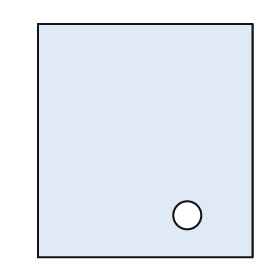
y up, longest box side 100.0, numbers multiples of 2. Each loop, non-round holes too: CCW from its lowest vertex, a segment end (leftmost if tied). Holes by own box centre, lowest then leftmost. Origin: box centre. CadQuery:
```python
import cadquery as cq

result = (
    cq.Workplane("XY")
    .moveTo(-46.0, -50.0)
    .lineTo(46.0, -50.0)
    .lineTo(46.0, 50.0)
    .lineTo(-46.0, 50.0)
    .close()
    .moveTo(18.0, -32.0)
    .circle(6.0)
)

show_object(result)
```